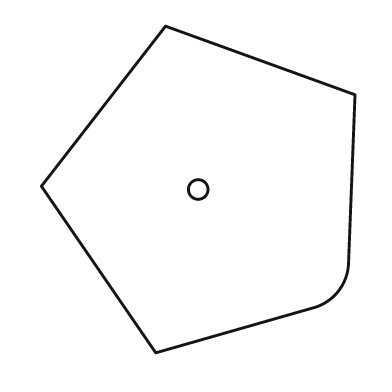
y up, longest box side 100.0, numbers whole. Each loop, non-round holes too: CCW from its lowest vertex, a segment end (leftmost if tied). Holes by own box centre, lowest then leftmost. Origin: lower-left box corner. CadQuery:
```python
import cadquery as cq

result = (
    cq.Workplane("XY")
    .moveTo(35.0, 0.0)
    .lineTo(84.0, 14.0)
    .threePointArc((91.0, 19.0), (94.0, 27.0))
    .lineTo(96.0, 79.0)
    .lineTo(38.0, 100.0)
    .lineTo(0.0, 51.0)
    .close()
    .moveTo(48.0, 50.0)
    .circle(3.0)
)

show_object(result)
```